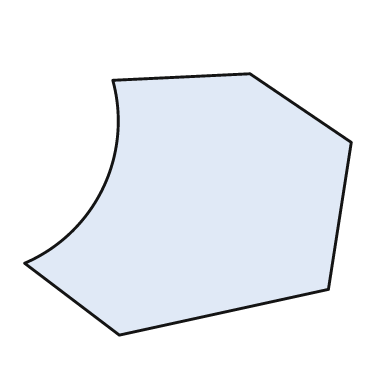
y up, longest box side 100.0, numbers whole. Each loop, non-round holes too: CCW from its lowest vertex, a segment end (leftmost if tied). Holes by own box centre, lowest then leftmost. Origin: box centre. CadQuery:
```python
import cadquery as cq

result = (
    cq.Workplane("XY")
    .moveTo(-21.0, -40.0)
    .lineTo(43.0, -26.0)
    .lineTo(50.0, 19.0)
    .lineTo(19.0, 40.0)
    .lineTo(-23.0, 38.0)
    .threePointArc((-26.0, 5.0), (-50.0, -18.0))
    .close()
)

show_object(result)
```